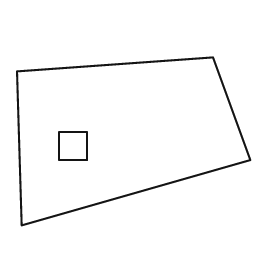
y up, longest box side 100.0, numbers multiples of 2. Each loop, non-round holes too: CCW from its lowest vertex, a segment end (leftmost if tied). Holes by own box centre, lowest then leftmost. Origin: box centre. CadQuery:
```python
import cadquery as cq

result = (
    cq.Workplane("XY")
    .moveTo(-48.0, -36.0)
    .lineTo(50.0, -8.0)
    .lineTo(34.0, 36.0)
    .lineTo(-50.0, 30.0)
    .close()
    .moveTo(-32.0, -8.0)
    .lineTo(-20.0, -8.0)
    .lineTo(-20.0, 4.0)
    .lineTo(-32.0, 4.0)
    .close()
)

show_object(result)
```